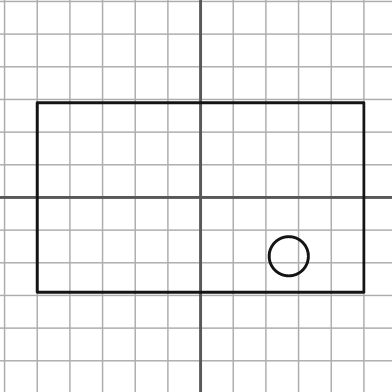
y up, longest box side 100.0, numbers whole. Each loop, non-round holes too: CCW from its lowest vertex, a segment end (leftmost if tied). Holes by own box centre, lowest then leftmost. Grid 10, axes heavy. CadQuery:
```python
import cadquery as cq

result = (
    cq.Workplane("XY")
    .moveTo(-50.0, -29.0)
    .lineTo(50.0, -29.0)
    .lineTo(50.0, 29.0)
    .lineTo(-50.0, 29.0)
    .close()
    .moveTo(27.0, -18.0)
    .circle(6.0)
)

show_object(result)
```